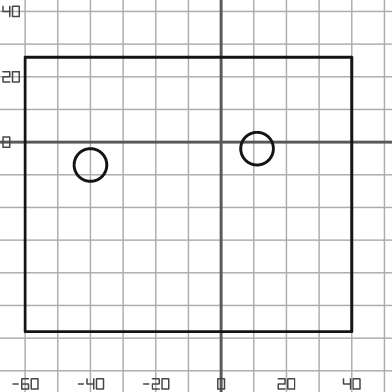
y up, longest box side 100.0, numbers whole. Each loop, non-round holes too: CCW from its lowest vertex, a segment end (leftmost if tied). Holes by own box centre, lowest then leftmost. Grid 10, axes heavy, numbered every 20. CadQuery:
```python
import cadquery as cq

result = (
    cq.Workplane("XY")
    .moveTo(-60.0, -58.0)
    .lineTo(40.0, -58.0)
    .lineTo(40.0, 26.0)
    .lineTo(-60.0, 26.0)
    .close()
    .moveTo(-40.0, -7.0)
    .circle(5.0)
    .moveTo(11.0, -2.0)
    .circle(5.0)
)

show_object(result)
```